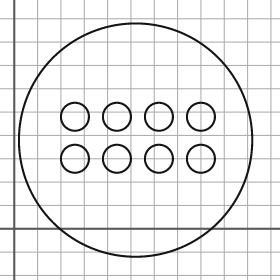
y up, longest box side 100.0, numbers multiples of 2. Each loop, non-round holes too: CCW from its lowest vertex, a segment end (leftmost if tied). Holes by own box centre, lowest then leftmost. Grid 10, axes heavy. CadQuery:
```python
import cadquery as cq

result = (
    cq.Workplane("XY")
    .moveTo(52.0, 38.0)
    .circle(50.0)
    .moveTo(26.0, 30.0)
    .circle(6.0)
    .moveTo(44.0, 30.0)
    .circle(6.0)
    .moveTo(62.0, 30.0)
    .circle(6.0)
    .moveTo(80.0, 30.0)
    .circle(6.0)
    .moveTo(26.0, 48.0)
    .circle(6.0)
    .moveTo(44.0, 48.0)
    .circle(6.0)
    .moveTo(62.0, 48.0)
    .circle(6.0)
    .moveTo(80.0, 48.0)
    .circle(6.0)
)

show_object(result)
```